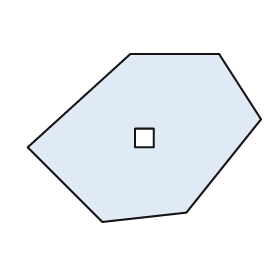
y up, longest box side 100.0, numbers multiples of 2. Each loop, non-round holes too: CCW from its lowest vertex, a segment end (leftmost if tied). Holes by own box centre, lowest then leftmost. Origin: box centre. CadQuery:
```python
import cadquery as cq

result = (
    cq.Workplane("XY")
    .moveTo(-18.0, -36.0)
    .lineTo(18.0, -32.0)
    .lineTo(50.0, 8.0)
    .lineTo(32.0, 36.0)
    .lineTo(-6.0, 36.0)
    .lineTo(-50.0, -4.0)
    .close()
    .moveTo(-4.0, -4.0)
    .lineTo(4.0, -4.0)
    .lineTo(4.0, 4.0)
    .lineTo(-4.0, 4.0)
    .close()
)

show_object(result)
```